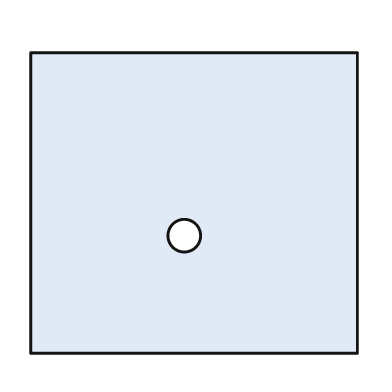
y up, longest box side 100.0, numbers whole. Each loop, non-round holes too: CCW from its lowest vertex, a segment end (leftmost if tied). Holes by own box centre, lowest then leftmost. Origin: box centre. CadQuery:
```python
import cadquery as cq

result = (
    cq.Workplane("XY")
    .moveTo(-50.0, -46.0)
    .lineTo(50.0, -46.0)
    .lineTo(50.0, 46.0)
    .lineTo(-50.0, 46.0)
    .close()
    .moveTo(-3.0, -10.0)
    .circle(5.0)
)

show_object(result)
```